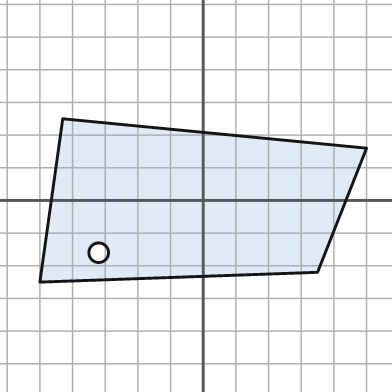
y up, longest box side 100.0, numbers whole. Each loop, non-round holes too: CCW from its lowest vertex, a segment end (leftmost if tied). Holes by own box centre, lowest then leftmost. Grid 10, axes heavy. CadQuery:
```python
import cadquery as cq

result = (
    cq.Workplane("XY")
    .moveTo(-50.0, -25.0)
    .lineTo(35.0, -22.0)
    .lineTo(50.0, 16.0)
    .lineTo(-43.0, 25.0)
    .close()
    .moveTo(-32.0, -16.0)
    .circle(3.0)
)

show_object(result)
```